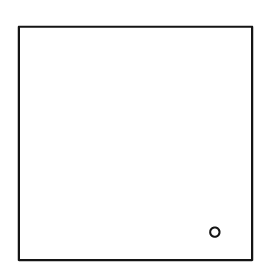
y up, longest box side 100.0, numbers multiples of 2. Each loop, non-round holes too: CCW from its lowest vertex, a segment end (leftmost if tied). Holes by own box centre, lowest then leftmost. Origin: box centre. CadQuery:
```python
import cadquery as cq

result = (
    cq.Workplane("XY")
    .moveTo(-50.0, -50.0)
    .lineTo(50.0, -50.0)
    .lineTo(50.0, 50.0)
    .lineTo(-50.0, 50.0)
    .close()
    .moveTo(34.0, -38.0)
    .circle(2.0)
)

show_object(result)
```